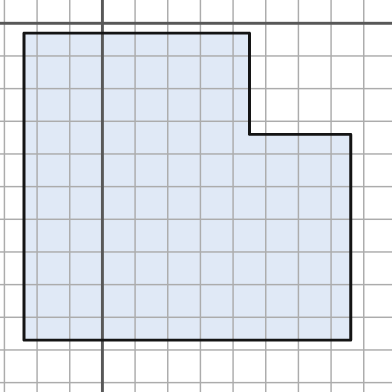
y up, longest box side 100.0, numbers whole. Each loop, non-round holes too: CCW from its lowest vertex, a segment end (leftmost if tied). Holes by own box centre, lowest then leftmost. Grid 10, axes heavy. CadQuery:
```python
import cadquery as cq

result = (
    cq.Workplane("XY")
    .moveTo(-24.0, -97.0)
    .lineTo(76.0, -97.0)
    .lineTo(76.0, -34.0)
    .lineTo(45.0, -34.0)
    .lineTo(45.0, -3.0)
    .lineTo(-24.0, -3.0)
    .close()
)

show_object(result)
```